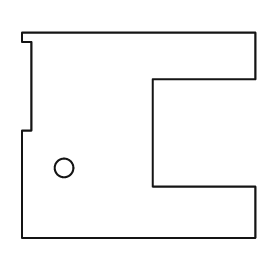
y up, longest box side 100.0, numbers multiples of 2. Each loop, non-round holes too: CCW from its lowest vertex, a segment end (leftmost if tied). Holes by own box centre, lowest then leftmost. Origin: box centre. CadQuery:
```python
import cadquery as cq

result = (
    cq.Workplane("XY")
    .moveTo(-50.0, -44.0)
    .lineTo(50.0, -44.0)
    .lineTo(50.0, -22.0)
    .lineTo(6.0, -22.0)
    .lineTo(6.0, 24.0)
    .lineTo(50.0, 24.0)
    .lineTo(50.0, 44.0)
    .lineTo(-50.0, 44.0)
    .lineTo(-50.0, 40.0)
    .lineTo(-46.0, 40.0)
    .lineTo(-46.0, 2.0)
    .lineTo(-50.0, 2.0)
    .close()
    .moveTo(-32.0, -14.0)
    .circle(4.0)
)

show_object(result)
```